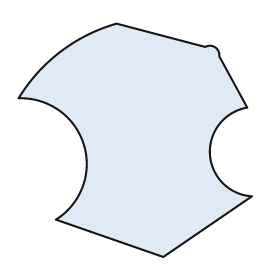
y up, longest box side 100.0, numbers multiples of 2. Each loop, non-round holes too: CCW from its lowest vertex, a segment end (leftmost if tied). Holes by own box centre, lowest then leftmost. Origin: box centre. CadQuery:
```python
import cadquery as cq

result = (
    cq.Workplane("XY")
    .moveTo(12.0, -50.0)
    .lineTo(50.0, -24.0)
    .threePointArc((32.0, -6.0), (48.0, 14.0))
    .lineTo(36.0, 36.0)
    .threePointArc((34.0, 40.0), (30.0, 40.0))
    .lineTo(-8.0, 50.0)
    .threePointArc((-32.0, 38.0), (-50.0, 18.0))
    .threePointArc((-22.0, -2.0), (-34.0, -34.0))
    .close()
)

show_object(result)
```